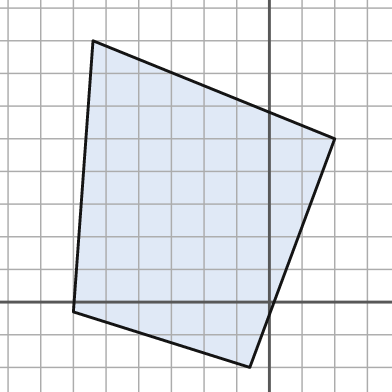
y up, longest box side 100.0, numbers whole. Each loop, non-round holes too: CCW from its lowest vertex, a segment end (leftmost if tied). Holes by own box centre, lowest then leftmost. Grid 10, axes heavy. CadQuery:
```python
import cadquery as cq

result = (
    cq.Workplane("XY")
    .moveTo(-6.0, -20.0)
    .lineTo(20.0, 50.0)
    .lineTo(-54.0, 80.0)
    .lineTo(-60.0, -3.0)
    .close()
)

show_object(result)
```